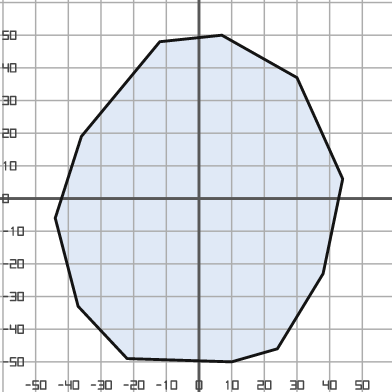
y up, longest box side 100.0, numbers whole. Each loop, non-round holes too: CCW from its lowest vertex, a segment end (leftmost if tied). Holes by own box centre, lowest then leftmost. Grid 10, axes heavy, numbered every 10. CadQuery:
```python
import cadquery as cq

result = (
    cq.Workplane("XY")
    .moveTo(10.0, -50.0)
    .lineTo(24.0, -46.0)
    .lineTo(38.0, -23.0)
    .lineTo(44.0, 6.0)
    .lineTo(30.0, 37.0)
    .lineTo(7.0, 50.0)
    .lineTo(-12.0, 48.0)
    .lineTo(-36.0, 19.0)
    .lineTo(-44.0, -6.0)
    .lineTo(-37.0, -33.0)
    .lineTo(-22.0, -49.0)
    .close()
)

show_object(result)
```